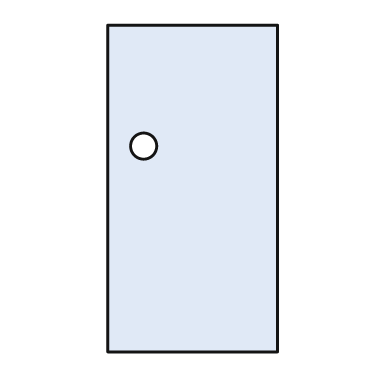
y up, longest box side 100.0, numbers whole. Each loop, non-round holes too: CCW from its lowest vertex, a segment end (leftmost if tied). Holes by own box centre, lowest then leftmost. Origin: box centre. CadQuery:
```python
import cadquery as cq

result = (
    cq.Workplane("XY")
    .moveTo(-26.0, -50.0)
    .lineTo(26.0, -50.0)
    .lineTo(26.0, 50.0)
    .lineTo(-26.0, 50.0)
    .close()
    .moveTo(-15.0, 13.0)
    .circle(4.0)
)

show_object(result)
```